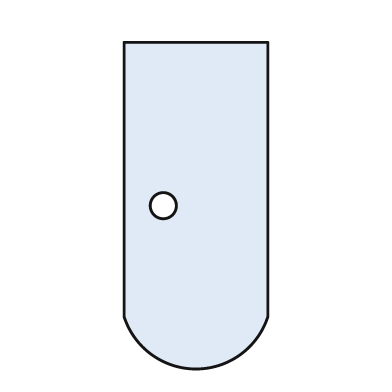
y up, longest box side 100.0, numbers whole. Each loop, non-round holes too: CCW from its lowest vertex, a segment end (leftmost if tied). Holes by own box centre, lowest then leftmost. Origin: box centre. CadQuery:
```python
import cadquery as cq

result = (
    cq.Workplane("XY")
    .moveTo(-22.0, -34.0)
    .threePointArc((0.0, -50.0), (22.0, -34.0))
    .lineTo(22.0, 50.0)
    .lineTo(-22.0, 50.0)
    .close()
    .moveTo(-10.0, 0.0)
    .circle(4.0)
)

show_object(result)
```